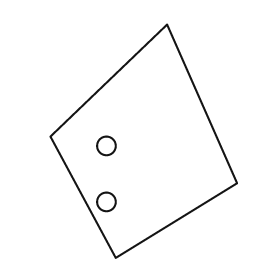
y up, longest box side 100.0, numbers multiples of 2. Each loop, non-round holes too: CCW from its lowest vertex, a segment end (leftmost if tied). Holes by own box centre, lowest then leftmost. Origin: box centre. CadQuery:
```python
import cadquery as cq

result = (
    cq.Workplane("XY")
    .moveTo(-12.0, -50.0)
    .lineTo(40.0, -18.0)
    .lineTo(10.0, 50.0)
    .lineTo(-40.0, 2.0)
    .close()
    .moveTo(-16.0, -26.0)
    .circle(4.0)
    .moveTo(-16.0, -2.0)
    .circle(4.0)
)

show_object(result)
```